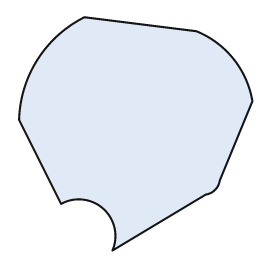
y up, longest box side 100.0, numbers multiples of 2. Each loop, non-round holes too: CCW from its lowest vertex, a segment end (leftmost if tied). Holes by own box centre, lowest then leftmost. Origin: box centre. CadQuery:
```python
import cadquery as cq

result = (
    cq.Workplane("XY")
    .moveTo(-10.0, -50.0)
    .lineTo(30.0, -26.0)
    .threePointArc((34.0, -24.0), (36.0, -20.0))
    .lineTo(50.0, 14.0)
    .threePointArc((42.0, 32.0), (26.0, 44.0))
    .lineTo(-22.0, 50.0)
    .threePointArc((-42.0, 32.0), (-50.0, 6.0))
    .lineTo(-32.0, -30.0)
    .threePointArc((-14.0, -32.0), (-10.0, -50.0))
    .close()
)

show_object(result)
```